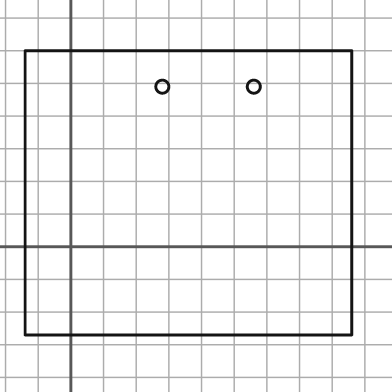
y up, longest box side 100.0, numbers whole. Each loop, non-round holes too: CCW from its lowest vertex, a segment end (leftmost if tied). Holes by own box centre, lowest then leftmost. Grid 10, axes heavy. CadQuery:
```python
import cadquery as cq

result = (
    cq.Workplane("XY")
    .moveTo(-14.0, -27.0)
    .lineTo(86.0, -27.0)
    .lineTo(86.0, 60.0)
    .lineTo(-14.0, 60.0)
    .close()
    .moveTo(28.0, 49.0)
    .circle(2.0)
    .moveTo(56.0, 49.0)
    .circle(2.0)
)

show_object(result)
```